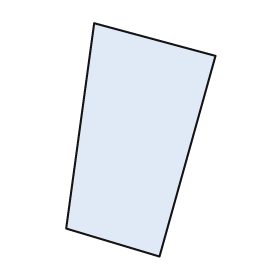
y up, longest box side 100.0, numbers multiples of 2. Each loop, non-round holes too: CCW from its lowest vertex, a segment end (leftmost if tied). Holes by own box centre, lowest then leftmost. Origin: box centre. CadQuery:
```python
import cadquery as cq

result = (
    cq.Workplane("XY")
    .moveTo(8.0, -50.0)
    .lineTo(32.0, 36.0)
    .lineTo(-20.0, 50.0)
    .lineTo(-32.0, -38.0)
    .close()
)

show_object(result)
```